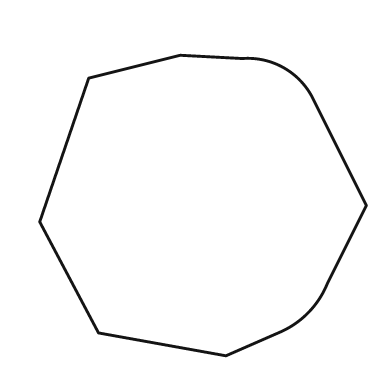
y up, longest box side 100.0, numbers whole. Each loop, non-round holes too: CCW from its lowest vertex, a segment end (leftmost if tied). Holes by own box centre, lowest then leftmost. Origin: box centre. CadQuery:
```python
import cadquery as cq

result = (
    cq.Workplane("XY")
    .moveTo(7.0, -46.0)
    .lineTo(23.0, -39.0)
    .threePointArc((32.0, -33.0), (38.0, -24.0))
    .lineTo(50.0, 0.0)
    .lineTo(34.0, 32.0)
    .threePointArc((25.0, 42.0), (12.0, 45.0))
    .lineTo(-7.0, 46.0)
    .lineTo(-35.0, 39.0)
    .lineTo(-50.0, -5.0)
    .lineTo(-32.0, -39.0)
    .close()
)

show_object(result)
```